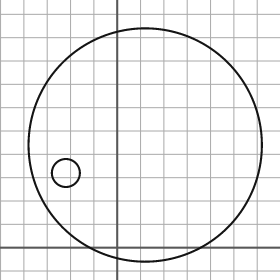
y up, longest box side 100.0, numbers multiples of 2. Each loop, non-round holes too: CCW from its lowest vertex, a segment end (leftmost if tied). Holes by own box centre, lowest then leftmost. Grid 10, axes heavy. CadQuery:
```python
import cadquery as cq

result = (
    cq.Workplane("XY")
    .moveTo(12.0, 44.0)
    .circle(50.0)
    .moveTo(-22.0, 32.0)
    .circle(6.0)
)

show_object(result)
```